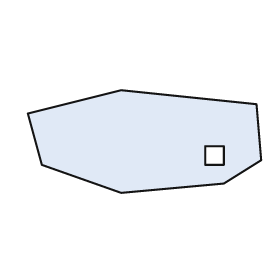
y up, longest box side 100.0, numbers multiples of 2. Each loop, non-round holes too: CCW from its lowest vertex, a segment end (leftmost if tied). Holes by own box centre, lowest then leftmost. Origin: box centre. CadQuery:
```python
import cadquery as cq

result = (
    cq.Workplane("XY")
    .moveTo(-10.0, -22.0)
    .lineTo(34.0, -18.0)
    .lineTo(50.0, -8.0)
    .lineTo(48.0, 16.0)
    .lineTo(-10.0, 22.0)
    .lineTo(-50.0, 12.0)
    .lineTo(-44.0, -10.0)
    .close()
    .moveTo(26.0, -10.0)
    .lineTo(34.0, -10.0)
    .lineTo(34.0, -2.0)
    .lineTo(26.0, -2.0)
    .close()
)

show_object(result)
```